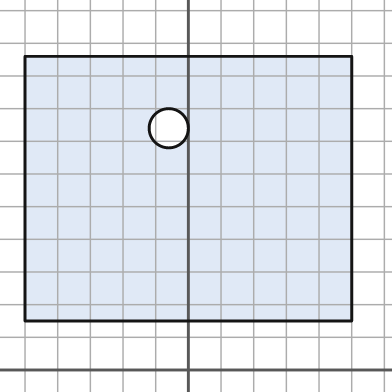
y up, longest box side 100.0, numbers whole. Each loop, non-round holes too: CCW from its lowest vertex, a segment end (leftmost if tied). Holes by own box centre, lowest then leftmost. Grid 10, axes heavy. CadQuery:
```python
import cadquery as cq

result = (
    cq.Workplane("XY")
    .moveTo(-50.0, 15.0)
    .lineTo(50.0, 15.0)
    .lineTo(50.0, 96.0)
    .lineTo(-50.0, 96.0)
    .close()
    .moveTo(-6.0, 74.0)
    .circle(6.0)
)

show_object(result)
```